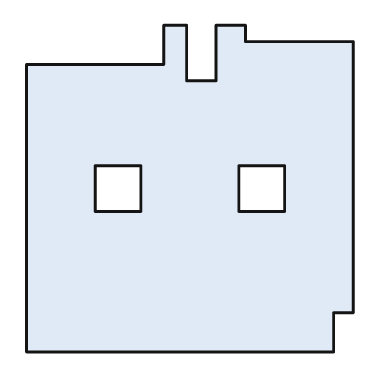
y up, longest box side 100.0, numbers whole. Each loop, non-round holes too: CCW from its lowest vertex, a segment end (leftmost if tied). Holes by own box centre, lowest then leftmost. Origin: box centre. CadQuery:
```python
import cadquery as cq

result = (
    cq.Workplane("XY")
    .moveTo(-50.0, -50.0)
    .lineTo(44.0, -50.0)
    .lineTo(44.0, -38.0)
    .lineTo(50.0, -38.0)
    .lineTo(50.0, 45.0)
    .lineTo(17.0, 45.0)
    .lineTo(17.0, 50.0)
    .lineTo(8.0, 50.0)
    .lineTo(8.0, 33.0)
    .lineTo(-1.0, 33.0)
    .lineTo(-1.0, 50.0)
    .lineTo(-8.0, 50.0)
    .lineTo(-8.0, 38.0)
    .lineTo(-50.0, 38.0)
    .close()
    .moveTo(-29.0, -7.0)
    .lineTo(-15.0, -7.0)
    .lineTo(-15.0, 7.0)
    .lineTo(-29.0, 7.0)
    .close()
    .moveTo(15.0, -7.0)
    .lineTo(29.0, -7.0)
    .lineTo(29.0, 7.0)
    .lineTo(15.0, 7.0)
    .close()
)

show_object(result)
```